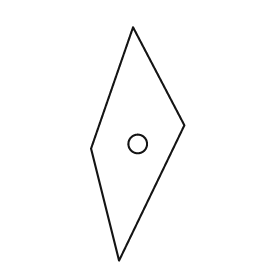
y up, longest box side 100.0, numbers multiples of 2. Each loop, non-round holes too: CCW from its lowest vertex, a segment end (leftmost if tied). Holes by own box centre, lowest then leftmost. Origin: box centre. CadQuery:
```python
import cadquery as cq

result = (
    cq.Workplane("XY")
    .moveTo(-8.0, -50.0)
    .lineTo(20.0, 8.0)
    .lineTo(-2.0, 50.0)
    .lineTo(-20.0, -2.0)
    .close()
    .moveTo(0.0, 0.0)
    .circle(4.0)
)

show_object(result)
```